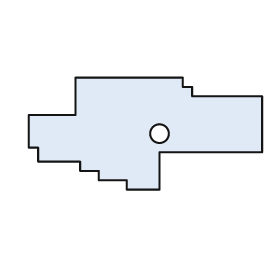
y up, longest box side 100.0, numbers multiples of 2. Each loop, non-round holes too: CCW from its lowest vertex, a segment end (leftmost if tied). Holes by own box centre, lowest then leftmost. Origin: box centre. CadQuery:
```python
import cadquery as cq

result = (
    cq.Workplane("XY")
    .moveTo(-8.0, -24.0)
    .lineTo(6.0, -24.0)
    .lineTo(6.0, -8.0)
    .lineTo(50.0, -8.0)
    .lineTo(50.0, 16.0)
    .lineTo(20.0, 16.0)
    .lineTo(20.0, 20.0)
    .lineTo(16.0, 20.0)
    .lineTo(16.0, 24.0)
    .lineTo(-30.0, 24.0)
    .lineTo(-30.0, 8.0)
    .lineTo(-50.0, 8.0)
    .lineTo(-50.0, -6.0)
    .lineTo(-46.0, -6.0)
    .lineTo(-46.0, -12.0)
    .lineTo(-28.0, -12.0)
    .lineTo(-28.0, -16.0)
    .lineTo(-20.0, -16.0)
    .lineTo(-20.0, -20.0)
    .lineTo(-8.0, -20.0)
    .close()
    .moveTo(6.0, 0.0)
    .circle(4.0)
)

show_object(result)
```